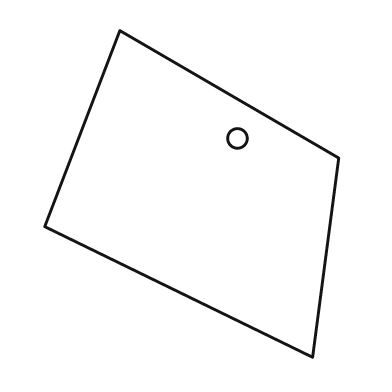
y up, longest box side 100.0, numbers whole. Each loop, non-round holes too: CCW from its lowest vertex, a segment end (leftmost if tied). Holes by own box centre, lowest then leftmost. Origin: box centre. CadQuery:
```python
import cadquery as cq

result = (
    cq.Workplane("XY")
    .moveTo(37.0, -50.0)
    .lineTo(45.0, 11.0)
    .lineTo(-22.0, 50.0)
    .lineTo(-45.0, -10.0)
    .close()
    .moveTo(14.0, 17.0)
    .circle(3.0)
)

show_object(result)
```